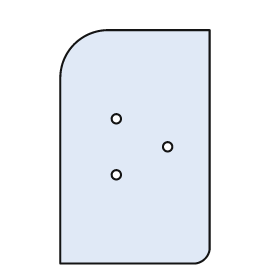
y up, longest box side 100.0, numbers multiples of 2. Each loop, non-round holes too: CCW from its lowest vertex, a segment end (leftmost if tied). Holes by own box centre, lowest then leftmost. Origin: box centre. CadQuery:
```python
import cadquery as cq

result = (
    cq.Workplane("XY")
    .moveTo(-32.0, -50.0)
    .lineTo(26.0, -50.0)
    .threePointArc((30.0, -48.0), (32.0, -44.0))
    .lineTo(32.0, 50.0)
    .lineTo(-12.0, 50.0)
    .threePointArc((-26.0, 44.0), (-32.0, 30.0))
    .close()
    .moveTo(-8.0, -12.0)
    .circle(2.0)
    .moveTo(14.0, 0.0)
    .circle(2.0)
    .moveTo(-8.0, 12.0)
    .circle(2.0)
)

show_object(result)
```